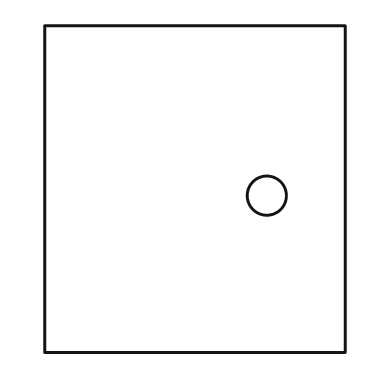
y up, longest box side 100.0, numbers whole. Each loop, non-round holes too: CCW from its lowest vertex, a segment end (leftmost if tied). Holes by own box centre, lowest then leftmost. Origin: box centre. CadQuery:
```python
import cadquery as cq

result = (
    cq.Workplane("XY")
    .moveTo(-46.0, -50.0)
    .lineTo(46.0, -50.0)
    .lineTo(46.0, 50.0)
    .lineTo(-46.0, 50.0)
    .close()
    .moveTo(22.0, -2.0)
    .circle(6.0)
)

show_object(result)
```